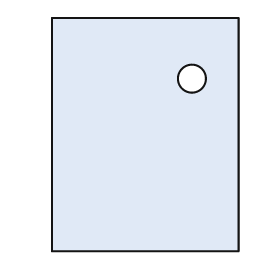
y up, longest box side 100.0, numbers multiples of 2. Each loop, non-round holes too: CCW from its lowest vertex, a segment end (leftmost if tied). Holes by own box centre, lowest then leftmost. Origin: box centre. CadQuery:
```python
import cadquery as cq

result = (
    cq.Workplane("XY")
    .moveTo(-40.0, -50.0)
    .lineTo(40.0, -50.0)
    .lineTo(40.0, 50.0)
    .lineTo(-40.0, 50.0)
    .close()
    .moveTo(20.0, 24.0)
    .circle(6.0)
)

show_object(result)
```